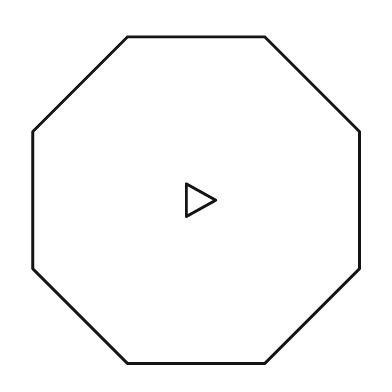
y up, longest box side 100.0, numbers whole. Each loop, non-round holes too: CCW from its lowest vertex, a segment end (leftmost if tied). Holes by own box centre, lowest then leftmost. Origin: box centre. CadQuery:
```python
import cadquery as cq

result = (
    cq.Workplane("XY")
    .moveTo(-21.0, -50.0)
    .lineTo(21.0, -50.0)
    .lineTo(50.0, -21.0)
    .lineTo(50.0, 21.0)
    .lineTo(21.0, 50.0)
    .lineTo(-21.0, 50.0)
    .lineTo(-50.0, 21.0)
    .lineTo(-50.0, -21.0)
    .close()
    .moveTo(-3.0, -5.0)
    .lineTo(6.0, 0.0)
    .lineTo(-3.0, 5.0)
    .close()
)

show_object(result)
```